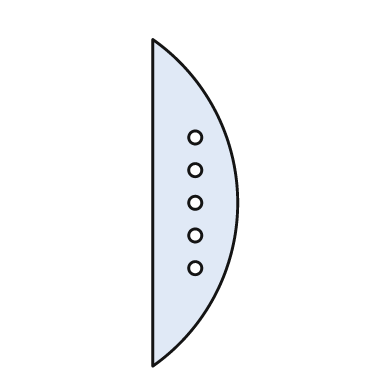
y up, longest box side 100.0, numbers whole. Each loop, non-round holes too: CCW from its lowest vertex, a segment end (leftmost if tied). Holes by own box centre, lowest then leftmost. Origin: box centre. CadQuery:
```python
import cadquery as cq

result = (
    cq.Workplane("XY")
    .moveTo(-13.0, -50.0)
    .threePointArc((13.0, 0.0), (-13.0, 50.0))
    .close()
    .moveTo(0.0, -20.0)
    .circle(2.0)
    .moveTo(0.0, -10.0)
    .circle(2.0)
    .moveTo(0.0, 0.0)
    .circle(2.0)
    .moveTo(0.0, 10.0)
    .circle(2.0)
    .moveTo(0.0, 20.0)
    .circle(2.0)
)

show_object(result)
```